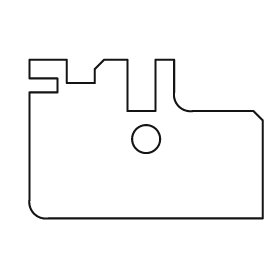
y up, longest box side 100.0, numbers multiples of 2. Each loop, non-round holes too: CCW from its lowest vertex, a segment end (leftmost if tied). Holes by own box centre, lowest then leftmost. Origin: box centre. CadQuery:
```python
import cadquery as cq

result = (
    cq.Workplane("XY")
    .moveTo(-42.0, -34.0)
    .lineTo(50.0, -34.0)
    .lineTo(50.0, 8.0)
    .lineTo(46.0, 12.0)
    .lineTo(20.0, 12.0)
    .threePointArc((14.0, 14.0), (12.0, 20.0))
    .lineTo(12.0, 34.0)
    .lineTo(4.0, 34.0)
    .lineTo(4.0, 12.0)
    .lineTo(-8.0, 12.0)
    .lineTo(-8.0, 34.0)
    .lineTo(-18.0, 34.0)
    .lineTo(-22.0, 30.0)
    .lineTo(-22.0, 24.0)
    .lineTo(-34.0, 24.0)
    .lineTo(-34.0, 34.0)
    .lineTo(-50.0, 34.0)
    .lineTo(-50.0, 26.0)
    .lineTo(-38.0, 26.0)
    .lineTo(-38.0, 20.0)
    .lineTo(-50.0, 20.0)
    .lineTo(-50.0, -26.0)
    .threePointArc((-48.0, -32.0), (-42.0, -34.0))
    .close()
    .moveTo(0.0, 0.0)
    .circle(6.0)
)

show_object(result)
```